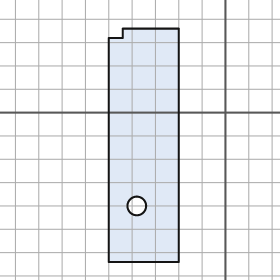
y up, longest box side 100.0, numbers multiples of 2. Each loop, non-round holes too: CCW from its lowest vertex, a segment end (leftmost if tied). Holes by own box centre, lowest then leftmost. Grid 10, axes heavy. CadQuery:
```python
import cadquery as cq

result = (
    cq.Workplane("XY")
    .moveTo(-50.0, -64.0)
    .lineTo(-20.0, -64.0)
    .lineTo(-20.0, 36.0)
    .lineTo(-44.0, 36.0)
    .lineTo(-44.0, 32.0)
    .lineTo(-50.0, 32.0)
    .close()
    .moveTo(-38.0, -40.0)
    .circle(4.0)
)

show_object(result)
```